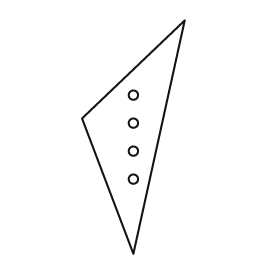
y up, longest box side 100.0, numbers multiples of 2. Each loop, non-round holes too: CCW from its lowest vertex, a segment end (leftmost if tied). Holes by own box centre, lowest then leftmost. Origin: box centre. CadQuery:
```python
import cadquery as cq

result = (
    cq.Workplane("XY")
    .moveTo(0.0, -50.0)
    .lineTo(22.0, 50.0)
    .lineTo(-22.0, 8.0)
    .close()
    .moveTo(0.0, -18.0)
    .circle(2.0)
    .moveTo(0.0, -6.0)
    .circle(2.0)
    .moveTo(0.0, 6.0)
    .circle(2.0)
    .moveTo(0.0, 18.0)
    .circle(2.0)
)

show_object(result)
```